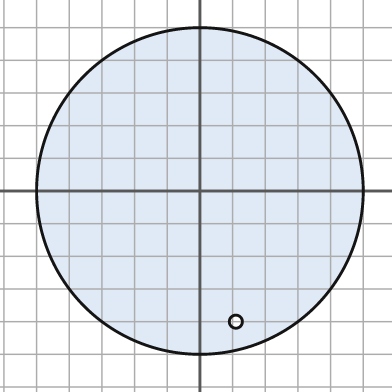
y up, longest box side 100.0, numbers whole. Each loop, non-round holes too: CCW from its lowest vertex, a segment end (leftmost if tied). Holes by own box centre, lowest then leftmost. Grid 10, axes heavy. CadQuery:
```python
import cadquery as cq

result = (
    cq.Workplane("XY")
    .moveTo(0.0, 0.0)
    .circle(50.0)
    .moveTo(11.0, -40.0)
    .circle(2.0)
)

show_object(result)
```